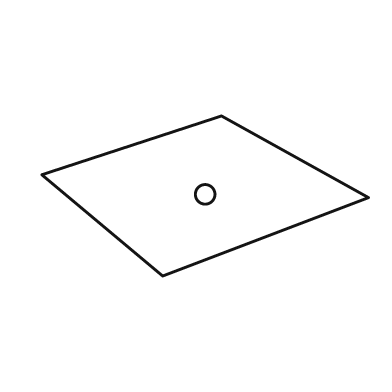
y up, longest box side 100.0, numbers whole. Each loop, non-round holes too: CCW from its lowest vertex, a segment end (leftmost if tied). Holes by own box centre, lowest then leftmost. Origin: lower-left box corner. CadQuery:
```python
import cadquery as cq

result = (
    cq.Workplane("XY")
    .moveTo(37.0, 0.0)
    .lineTo(100.0, 24.0)
    .lineTo(55.0, 49.0)
    .lineTo(0.0, 31.0)
    .close()
    .moveTo(50.0, 25.0)
    .circle(3.0)
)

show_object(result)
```